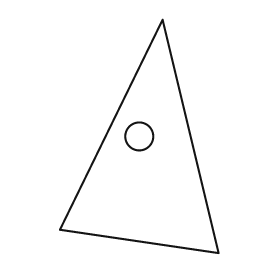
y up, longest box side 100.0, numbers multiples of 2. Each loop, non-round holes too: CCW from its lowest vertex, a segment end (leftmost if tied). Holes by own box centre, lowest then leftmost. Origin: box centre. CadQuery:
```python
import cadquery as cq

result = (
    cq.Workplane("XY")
    .moveTo(34.0, -50.0)
    .lineTo(10.0, 50.0)
    .lineTo(-34.0, -40.0)
    .close()
    .moveTo(0.0, 0.0)
    .circle(6.0)
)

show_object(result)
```